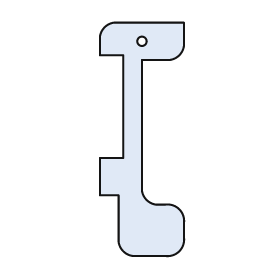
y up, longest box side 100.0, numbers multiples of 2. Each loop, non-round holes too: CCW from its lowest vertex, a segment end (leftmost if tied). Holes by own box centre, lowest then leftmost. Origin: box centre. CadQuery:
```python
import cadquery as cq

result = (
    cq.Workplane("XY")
    .moveTo(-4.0, -50.0)
    .lineTo(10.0, -50.0)
    .threePointArc((16.0, -48.0), (18.0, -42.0))
    .lineTo(18.0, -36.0)
    .threePointArc((16.0, -30.0), (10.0, -28.0))
    .lineTo(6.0, -28.0)
    .threePointArc((2.0, -26.0), (0.0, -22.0))
    .lineTo(0.0, 34.0)
    .lineTo(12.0, 34.0)
    .threePointArc((16.0, 36.0), (18.0, 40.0))
    .lineTo(18.0, 50.0)
    .lineTo(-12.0, 50.0)
    .threePointArc((-16.0, 48.0), (-18.0, 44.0))
    .lineTo(-18.0, 36.0)
    .lineTo(-8.0, 36.0)
    .lineTo(-8.0, -8.0)
    .lineTo(-18.0, -8.0)
    .lineTo(-18.0, -24.0)
    .lineTo(-10.0, -24.0)
    .lineTo(-10.0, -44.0)
    .threePointArc((-8.0, -48.0), (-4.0, -50.0))
    .close()
    .moveTo(0.0, 42.0)
    .circle(2.0)
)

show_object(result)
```